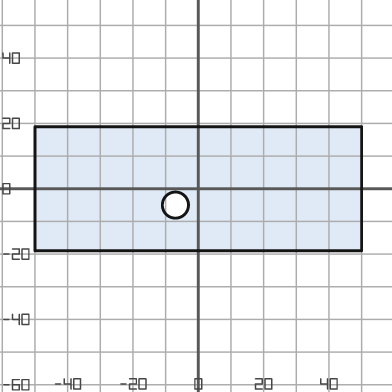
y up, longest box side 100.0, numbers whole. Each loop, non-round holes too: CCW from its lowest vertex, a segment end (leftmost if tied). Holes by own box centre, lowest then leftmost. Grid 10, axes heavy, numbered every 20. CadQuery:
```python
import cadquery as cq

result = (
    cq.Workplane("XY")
    .moveTo(-50.0, -19.0)
    .lineTo(50.0, -19.0)
    .lineTo(50.0, 19.0)
    .lineTo(-50.0, 19.0)
    .close()
    .moveTo(-7.0, -5.0)
    .circle(4.0)
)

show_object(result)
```